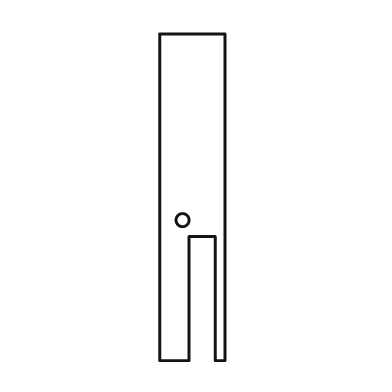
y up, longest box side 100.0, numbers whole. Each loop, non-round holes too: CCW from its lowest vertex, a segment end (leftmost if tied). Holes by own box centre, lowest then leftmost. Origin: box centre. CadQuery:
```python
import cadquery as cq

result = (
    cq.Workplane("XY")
    .moveTo(-10.0, -50.0)
    .lineTo(-1.0, -50.0)
    .lineTo(-1.0, -12.0)
    .lineTo(7.0, -12.0)
    .lineTo(7.0, -50.0)
    .lineTo(10.0, -50.0)
    .lineTo(10.0, 50.0)
    .lineTo(-10.0, 50.0)
    .close()
    .moveTo(-3.0, -7.0)
    .circle(2.0)
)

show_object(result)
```